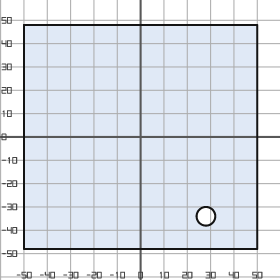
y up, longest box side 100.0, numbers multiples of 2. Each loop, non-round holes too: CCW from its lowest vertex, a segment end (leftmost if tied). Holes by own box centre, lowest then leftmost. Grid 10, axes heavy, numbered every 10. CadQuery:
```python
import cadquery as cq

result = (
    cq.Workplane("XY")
    .moveTo(-50.0, -48.0)
    .lineTo(50.0, -48.0)
    .lineTo(50.0, 48.0)
    .lineTo(-50.0, 48.0)
    .close()
    .moveTo(28.0, -34.0)
    .circle(4.0)
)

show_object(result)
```